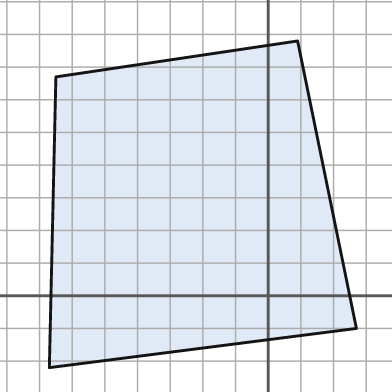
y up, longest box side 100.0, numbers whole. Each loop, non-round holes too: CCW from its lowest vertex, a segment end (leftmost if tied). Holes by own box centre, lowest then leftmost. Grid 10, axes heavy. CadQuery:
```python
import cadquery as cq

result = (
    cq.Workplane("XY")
    .moveTo(-67.0, -22.0)
    .lineTo(27.0, -10.0)
    .lineTo(9.0, 78.0)
    .lineTo(-65.0, 67.0)
    .close()
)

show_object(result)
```